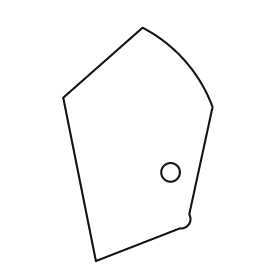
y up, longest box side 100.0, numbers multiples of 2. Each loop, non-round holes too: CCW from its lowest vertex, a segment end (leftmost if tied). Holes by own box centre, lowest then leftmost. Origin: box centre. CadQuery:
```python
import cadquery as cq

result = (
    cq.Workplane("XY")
    .moveTo(-18.0, -50.0)
    .lineTo(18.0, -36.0)
    .threePointArc((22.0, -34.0), (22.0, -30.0))
    .lineTo(32.0, 16.0)
    .threePointArc((20.0, 36.0), (2.0, 50.0))
    .lineTo(-32.0, 20.0)
    .close()
    .moveTo(14.0, -12.0)
    .circle(4.0)
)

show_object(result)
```